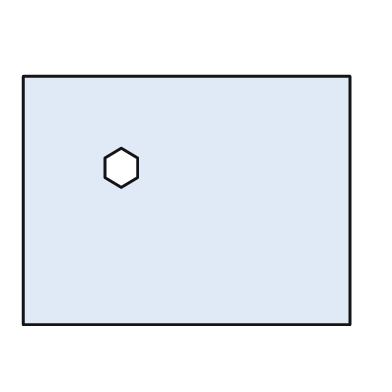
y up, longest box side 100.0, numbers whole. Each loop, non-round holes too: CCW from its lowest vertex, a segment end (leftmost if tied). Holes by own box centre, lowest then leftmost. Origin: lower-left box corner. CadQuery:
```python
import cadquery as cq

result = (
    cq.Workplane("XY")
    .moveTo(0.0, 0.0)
    .lineTo(100.0, 0.0)
    .lineTo(100.0, 76.0)
    .lineTo(0.0, 76.0)
    .close()
    .moveTo(30.0, 42.0)
    .lineTo(35.0, 45.0)
    .lineTo(35.0, 51.0)
    .lineTo(30.0, 54.0)
    .lineTo(25.0, 51.0)
    .lineTo(25.0, 45.0)
    .close()
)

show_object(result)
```